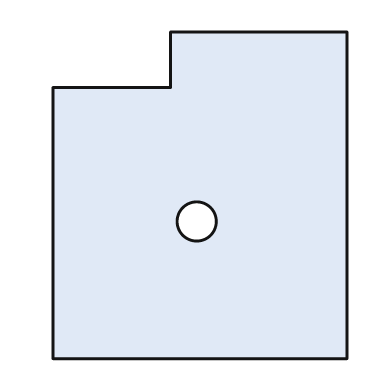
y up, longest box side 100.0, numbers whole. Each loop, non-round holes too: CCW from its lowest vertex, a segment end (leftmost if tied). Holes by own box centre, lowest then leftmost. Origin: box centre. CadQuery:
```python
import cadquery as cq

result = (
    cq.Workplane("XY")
    .moveTo(-45.0, -50.0)
    .lineTo(45.0, -50.0)
    .lineTo(45.0, 50.0)
    .lineTo(-9.0, 50.0)
    .lineTo(-9.0, 33.0)
    .lineTo(-45.0, 33.0)
    .close()
    .moveTo(-1.0, -8.0)
    .circle(6.0)
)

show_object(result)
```